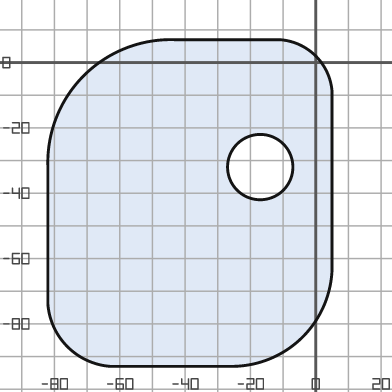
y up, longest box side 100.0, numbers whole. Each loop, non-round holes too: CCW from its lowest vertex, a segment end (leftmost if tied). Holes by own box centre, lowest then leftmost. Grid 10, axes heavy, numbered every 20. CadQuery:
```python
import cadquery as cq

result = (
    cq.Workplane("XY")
    .moveTo(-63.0, -93.0)
    .lineTo(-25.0, -93.0)
    .threePointArc((-4.0, -84.0), (5.0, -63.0))
    .lineTo(5.0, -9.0)
    .threePointArc((0.0, 2.0), (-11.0, 7.0))
    .lineTo(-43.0, 7.0)
    .threePointArc((-71.0, -4.0), (-82.0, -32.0))
    .lineTo(-82.0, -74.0)
    .threePointArc((-76.0, -87.0), (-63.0, -93.0))
    .close()
    .moveTo(-17.0, -32.0)
    .circle(10.0)
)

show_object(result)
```